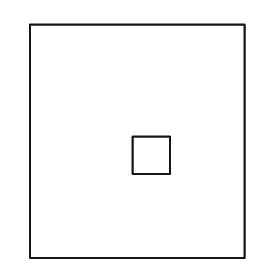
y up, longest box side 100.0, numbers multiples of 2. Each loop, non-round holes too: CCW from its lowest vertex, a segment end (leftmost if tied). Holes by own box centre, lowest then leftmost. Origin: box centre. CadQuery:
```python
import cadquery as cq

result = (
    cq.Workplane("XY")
    .moveTo(-46.0, -50.0)
    .lineTo(46.0, -50.0)
    .lineTo(46.0, 50.0)
    .lineTo(-46.0, 50.0)
    .close()
    .moveTo(-2.0, -14.0)
    .lineTo(14.0, -14.0)
    .lineTo(14.0, 2.0)
    .lineTo(-2.0, 2.0)
    .close()
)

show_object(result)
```